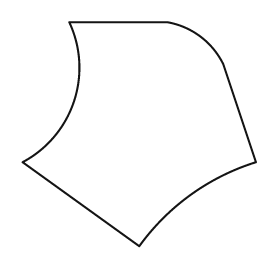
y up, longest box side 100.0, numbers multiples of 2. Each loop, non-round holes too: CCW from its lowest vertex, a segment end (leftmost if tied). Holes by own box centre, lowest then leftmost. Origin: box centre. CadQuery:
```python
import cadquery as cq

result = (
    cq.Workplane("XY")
    .moveTo(0.0, -48.0)
    .threePointArc((22.0, -26.0), (50.0, -12.0))
    .lineTo(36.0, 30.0)
    .threePointArc((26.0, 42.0), (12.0, 48.0))
    .lineTo(-30.0, 48.0)
    .threePointArc((-28.0, 14.0), (-50.0, -12.0))
    .close()
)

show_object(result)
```